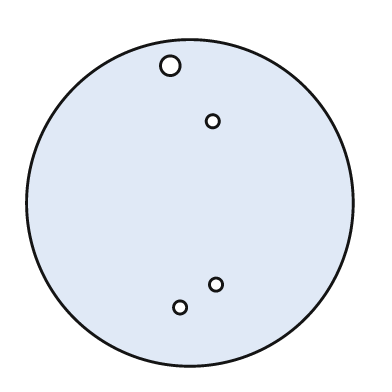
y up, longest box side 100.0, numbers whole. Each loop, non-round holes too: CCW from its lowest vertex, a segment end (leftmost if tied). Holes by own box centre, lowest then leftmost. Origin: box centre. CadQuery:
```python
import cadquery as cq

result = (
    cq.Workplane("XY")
    .moveTo(0.0, 0.0)
    .circle(50.0)
    .moveTo(-3.0, -32.0)
    .circle(2.0)
    .moveTo(8.0, -25.0)
    .circle(2.0)
    .moveTo(7.0, 25.0)
    .circle(2.0)
    .moveTo(-6.0, 42.0)
    .circle(3.0)
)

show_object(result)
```